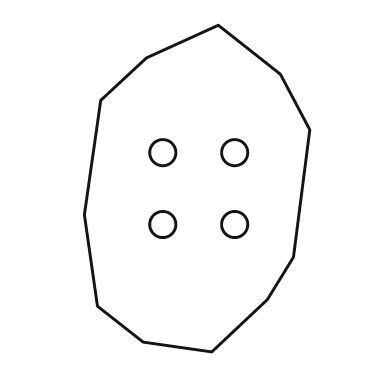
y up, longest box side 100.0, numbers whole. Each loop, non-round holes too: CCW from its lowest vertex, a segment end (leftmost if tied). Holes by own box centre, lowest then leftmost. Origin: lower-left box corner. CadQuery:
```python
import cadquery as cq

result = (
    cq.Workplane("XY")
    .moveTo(39.0, 0.0)
    .lineTo(56.0, 16.0)
    .lineTo(64.0, 29.0)
    .lineTo(69.0, 68.0)
    .lineTo(60.0, 85.0)
    .lineTo(41.0, 100.0)
    .lineTo(19.0, 90.0)
    .lineTo(5.0, 77.0)
    .lineTo(0.0, 42.0)
    .lineTo(4.0, 14.0)
    .lineTo(18.0, 3.0)
    .close()
    .moveTo(24.0, 39.0)
    .circle(4.0)
    .moveTo(46.0, 39.0)
    .circle(4.0)
    .moveTo(24.0, 61.0)
    .circle(4.0)
    .moveTo(46.0, 61.0)
    .circle(4.0)
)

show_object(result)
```